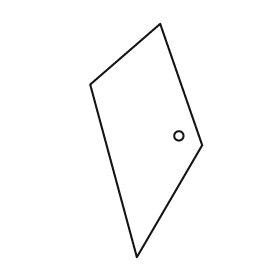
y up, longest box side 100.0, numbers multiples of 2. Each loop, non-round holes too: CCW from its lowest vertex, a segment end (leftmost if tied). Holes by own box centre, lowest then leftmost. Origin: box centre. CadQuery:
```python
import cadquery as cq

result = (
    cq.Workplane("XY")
    .moveTo(-4.0, -50.0)
    .lineTo(24.0, -2.0)
    .lineTo(6.0, 50.0)
    .lineTo(-24.0, 24.0)
    .close()
    .moveTo(14.0, 2.0)
    .circle(2.0)
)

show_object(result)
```